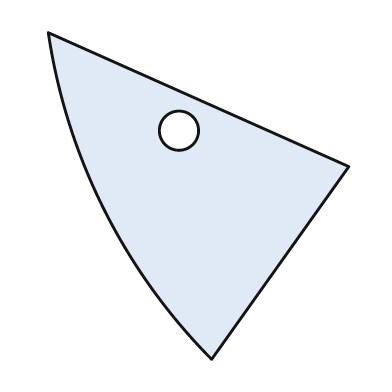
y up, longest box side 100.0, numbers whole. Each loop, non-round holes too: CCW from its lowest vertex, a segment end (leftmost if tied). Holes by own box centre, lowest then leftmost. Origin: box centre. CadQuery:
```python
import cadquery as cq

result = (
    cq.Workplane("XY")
    .moveTo(4.0, -50.0)
    .lineTo(46.0, 9.0)
    .lineTo(-46.0, 50.0)
    .threePointArc((-29.0, -4.0), (4.0, -50.0))
    .close()
    .moveTo(-6.0, 20.0)
    .circle(6.0)
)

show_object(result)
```